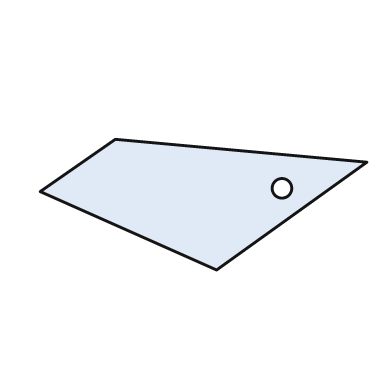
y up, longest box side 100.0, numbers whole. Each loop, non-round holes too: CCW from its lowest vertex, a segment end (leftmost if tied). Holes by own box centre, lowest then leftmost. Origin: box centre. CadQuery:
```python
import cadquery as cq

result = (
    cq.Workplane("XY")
    .moveTo(4.0, -20.0)
    .lineTo(50.0, 13.0)
    .lineTo(-27.0, 20.0)
    .lineTo(-50.0, 4.0)
    .close()
    .moveTo(24.0, 5.0)
    .circle(3.0)
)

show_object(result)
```